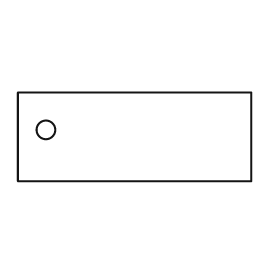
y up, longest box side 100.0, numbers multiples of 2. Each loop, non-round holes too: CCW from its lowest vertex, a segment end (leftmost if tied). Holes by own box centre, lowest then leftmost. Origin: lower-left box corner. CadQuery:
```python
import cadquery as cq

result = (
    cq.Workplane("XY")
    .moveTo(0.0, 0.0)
    .lineTo(100.0, 0.0)
    .lineTo(100.0, 38.0)
    .lineTo(0.0, 38.0)
    .close()
    .moveTo(12.0, 22.0)
    .circle(4.0)
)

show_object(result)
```